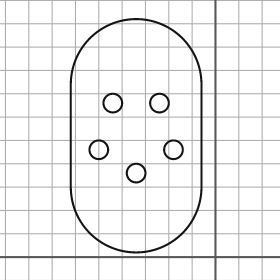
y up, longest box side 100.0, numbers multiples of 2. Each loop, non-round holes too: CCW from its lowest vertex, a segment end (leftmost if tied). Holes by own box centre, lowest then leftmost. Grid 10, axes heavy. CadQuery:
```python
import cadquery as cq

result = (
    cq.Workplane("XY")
    .moveTo(-62.0, 30.0)
    .threePointArc((-34.0, 2.0), (-6.0, 30.0))
    .lineTo(-6.0, 74.0)
    .threePointArc((-34.0, 102.0), (-62.0, 74.0))
    .close()
    .moveTo(-34.0, 36.0)
    .circle(4.0)
    .moveTo(-50.0, 46.0)
    .circle(4.0)
    .moveTo(-18.0, 46.0)
    .circle(4.0)
    .moveTo(-44.0, 66.0)
    .circle(4.0)
    .moveTo(-24.0, 66.0)
    .circle(4.0)
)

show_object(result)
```